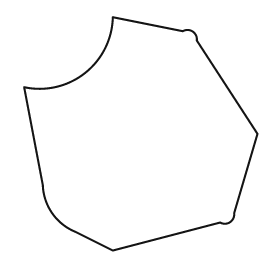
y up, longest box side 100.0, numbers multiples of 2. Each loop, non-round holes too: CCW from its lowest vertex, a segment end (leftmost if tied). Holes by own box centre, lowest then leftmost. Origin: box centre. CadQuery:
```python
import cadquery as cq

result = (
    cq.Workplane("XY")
    .moveTo(-12.0, -50.0)
    .lineTo(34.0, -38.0)
    .threePointArc((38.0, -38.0), (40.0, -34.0))
    .lineTo(50.0, 0.0)
    .lineTo(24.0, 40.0)
    .threePointArc((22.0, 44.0), (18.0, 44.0))
    .lineTo(-12.0, 50.0)
    .threePointArc((-24.0, 26.0), (-50.0, 20.0))
    .lineTo(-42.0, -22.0)
    .threePointArc((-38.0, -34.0), (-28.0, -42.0))
    .close()
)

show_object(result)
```